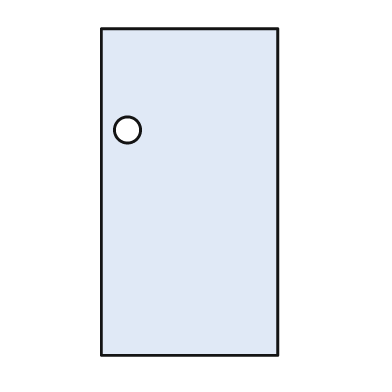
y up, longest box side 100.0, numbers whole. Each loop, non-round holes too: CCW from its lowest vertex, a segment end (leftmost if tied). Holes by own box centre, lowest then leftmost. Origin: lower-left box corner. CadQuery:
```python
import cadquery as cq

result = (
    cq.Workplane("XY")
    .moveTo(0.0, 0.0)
    .lineTo(54.0, 0.0)
    .lineTo(54.0, 100.0)
    .lineTo(0.0, 100.0)
    .close()
    .moveTo(8.0, 69.0)
    .circle(4.0)
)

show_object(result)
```